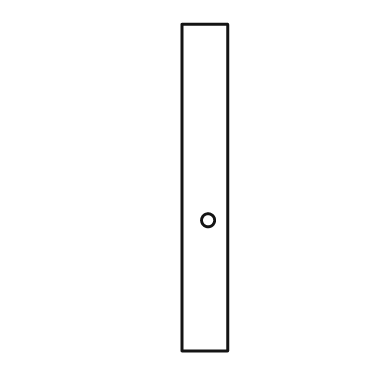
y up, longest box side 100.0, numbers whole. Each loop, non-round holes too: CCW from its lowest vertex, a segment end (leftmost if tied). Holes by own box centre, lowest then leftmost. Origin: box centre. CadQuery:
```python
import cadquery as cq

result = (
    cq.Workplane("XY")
    .moveTo(-7.0, -50.0)
    .lineTo(7.0, -50.0)
    .lineTo(7.0, 50.0)
    .lineTo(-7.0, 50.0)
    .close()
    .moveTo(1.0, -10.0)
    .circle(2.0)
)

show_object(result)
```